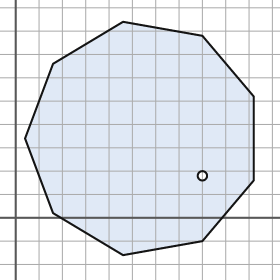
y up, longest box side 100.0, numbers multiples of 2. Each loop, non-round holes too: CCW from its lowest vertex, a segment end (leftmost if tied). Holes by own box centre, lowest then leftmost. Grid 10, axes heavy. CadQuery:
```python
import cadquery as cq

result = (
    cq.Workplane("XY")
    .moveTo(46.0, -16.0)
    .lineTo(80.0, -10.0)
    .lineTo(102.0, 16.0)
    .lineTo(102.0, 52.0)
    .lineTo(80.0, 78.0)
    .lineTo(46.0, 84.0)
    .lineTo(16.0, 66.0)
    .lineTo(4.0, 34.0)
    .lineTo(16.0, 2.0)
    .close()
    .moveTo(80.0, 18.0)
    .circle(2.0)
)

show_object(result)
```